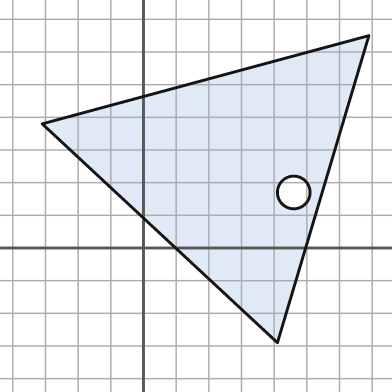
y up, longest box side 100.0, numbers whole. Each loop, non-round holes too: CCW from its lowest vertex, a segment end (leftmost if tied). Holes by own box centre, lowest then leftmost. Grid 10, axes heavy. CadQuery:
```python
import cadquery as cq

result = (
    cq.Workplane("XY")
    .moveTo(41.0, -29.0)
    .lineTo(69.0, 65.0)
    .lineTo(-31.0, 38.0)
    .close()
    .moveTo(46.0, 17.0)
    .circle(5.0)
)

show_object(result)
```